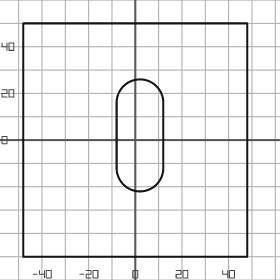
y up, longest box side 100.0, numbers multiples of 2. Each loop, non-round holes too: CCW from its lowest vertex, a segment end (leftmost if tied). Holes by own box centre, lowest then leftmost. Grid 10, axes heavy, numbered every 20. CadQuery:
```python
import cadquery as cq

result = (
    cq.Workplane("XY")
    .moveTo(-48.0, -50.0)
    .lineTo(48.0, -50.0)
    .lineTo(48.0, 50.0)
    .lineTo(-48.0, 50.0)
    .close()
    .moveTo(-8.0, -12.0)
    .threePointArc((2.0, -22.0), (12.0, -12.0))
    .lineTo(12.0, 16.0)
    .threePointArc((2.0, 26.0), (-8.0, 16.0))
    .close()
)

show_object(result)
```